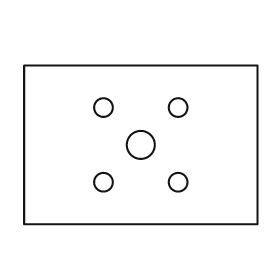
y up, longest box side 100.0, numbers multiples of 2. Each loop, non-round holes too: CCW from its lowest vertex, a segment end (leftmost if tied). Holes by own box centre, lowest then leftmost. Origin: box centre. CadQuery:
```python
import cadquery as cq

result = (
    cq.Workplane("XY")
    .moveTo(-50.0, -34.0)
    .lineTo(50.0, -34.0)
    .lineTo(50.0, 34.0)
    .lineTo(-50.0, 34.0)
    .close()
    .moveTo(-16.0, -16.0)
    .circle(4.0)
    .moveTo(16.0, -16.0)
    .circle(4.0)
    .moveTo(0.0, 0.0)
    .circle(6.0)
    .moveTo(-16.0, 16.0)
    .circle(4.0)
    .moveTo(16.0, 16.0)
    .circle(4.0)
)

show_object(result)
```